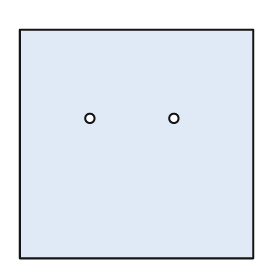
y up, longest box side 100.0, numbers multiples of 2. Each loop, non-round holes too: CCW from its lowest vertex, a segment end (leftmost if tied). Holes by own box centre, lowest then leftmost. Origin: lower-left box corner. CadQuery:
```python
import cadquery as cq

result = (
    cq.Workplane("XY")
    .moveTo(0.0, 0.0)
    .lineTo(100.0, 0.0)
    .lineTo(100.0, 98.0)
    .lineTo(0.0, 98.0)
    .close()
    .moveTo(30.0, 60.0)
    .circle(2.0)
    .moveTo(66.0, 60.0)
    .circle(2.0)
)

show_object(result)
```